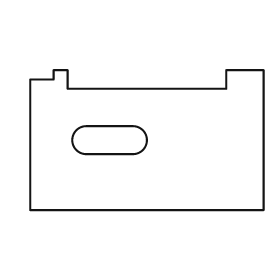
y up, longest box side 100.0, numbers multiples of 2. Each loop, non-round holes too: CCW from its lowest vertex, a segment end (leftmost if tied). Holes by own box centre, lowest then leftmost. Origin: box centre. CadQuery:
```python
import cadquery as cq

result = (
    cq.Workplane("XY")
    .moveTo(-50.0, -30.0)
    .lineTo(50.0, -30.0)
    .lineTo(50.0, 30.0)
    .lineTo(34.0, 30.0)
    .lineTo(34.0, 22.0)
    .lineTo(-34.0, 22.0)
    .lineTo(-34.0, 30.0)
    .lineTo(-40.0, 30.0)
    .lineTo(-40.0, 26.0)
    .lineTo(-50.0, 26.0)
    .close()
    .moveTo(-26.0, -6.0)
    .lineTo(-6.0, -6.0)
    .threePointArc((0.0, 0.0), (-6.0, 6.0))
    .lineTo(-26.0, 6.0)
    .threePointArc((-32.0, 0.0), (-26.0, -6.0))
    .close()
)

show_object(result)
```